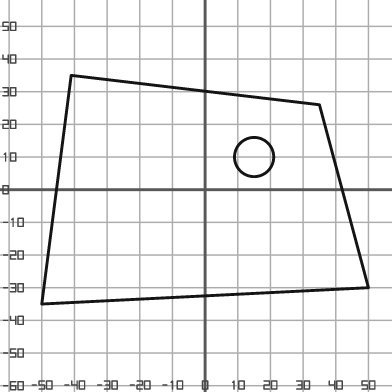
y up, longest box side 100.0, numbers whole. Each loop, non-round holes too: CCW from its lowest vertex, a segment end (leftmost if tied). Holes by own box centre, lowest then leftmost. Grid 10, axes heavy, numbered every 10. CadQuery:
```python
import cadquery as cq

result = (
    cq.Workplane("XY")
    .moveTo(-50.0, -35.0)
    .lineTo(50.0, -30.0)
    .lineTo(35.0, 26.0)
    .lineTo(-41.0, 35.0)
    .close()
    .moveTo(15.0, 10.0)
    .circle(6.0)
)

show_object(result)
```